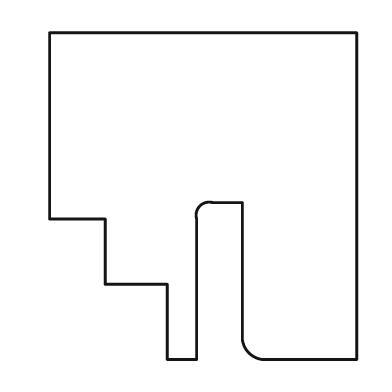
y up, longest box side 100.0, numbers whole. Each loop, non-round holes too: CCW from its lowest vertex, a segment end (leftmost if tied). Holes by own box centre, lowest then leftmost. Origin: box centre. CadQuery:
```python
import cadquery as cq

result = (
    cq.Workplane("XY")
    .moveTo(-11.0, -50.0)
    .lineTo(-2.0, -50.0)
    .lineTo(-2.0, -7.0)
    .threePointArc((-1.0, -3.0), (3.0, -2.0))
    .lineTo(12.0, -2.0)
    .lineTo(12.0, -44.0)
    .threePointArc((14.0, -48.0), (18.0, -50.0))
    .lineTo(47.0, -50.0)
    .lineTo(47.0, 50.0)
    .lineTo(-47.0, 50.0)
    .lineTo(-47.0, -7.0)
    .lineTo(-30.0, -7.0)
    .lineTo(-30.0, -27.0)
    .lineTo(-11.0, -27.0)
    .close()
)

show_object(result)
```